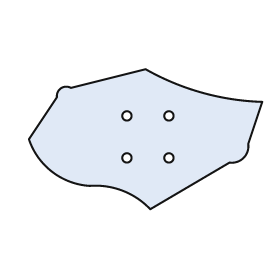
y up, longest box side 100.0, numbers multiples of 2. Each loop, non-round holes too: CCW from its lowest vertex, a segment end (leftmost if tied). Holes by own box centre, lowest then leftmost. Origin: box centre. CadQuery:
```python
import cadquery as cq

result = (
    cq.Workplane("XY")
    .moveTo(2.0, -30.0)
    .lineTo(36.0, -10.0)
    .threePointArc((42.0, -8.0), (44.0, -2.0))
    .lineTo(50.0, 16.0)
    .threePointArc((24.0, 20.0), (0.0, 30.0))
    .lineTo(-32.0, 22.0)
    .threePointArc((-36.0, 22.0), (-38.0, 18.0))
    .lineTo(-50.0, 0.0)
    .threePointArc((-40.0, -14.0), (-24.0, -20.0))
    .threePointArc((-10.0, -22.0), (2.0, -30.0))
    .close()
    .moveTo(-8.0, -8.0)
    .circle(2.0)
    .moveTo(10.0, -8.0)
    .circle(2.0)
    .moveTo(-8.0, 10.0)
    .circle(2.0)
    .moveTo(10.0, 10.0)
    .circle(2.0)
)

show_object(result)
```